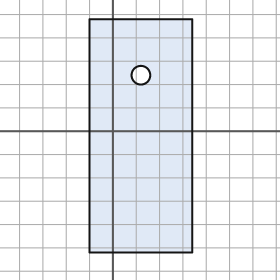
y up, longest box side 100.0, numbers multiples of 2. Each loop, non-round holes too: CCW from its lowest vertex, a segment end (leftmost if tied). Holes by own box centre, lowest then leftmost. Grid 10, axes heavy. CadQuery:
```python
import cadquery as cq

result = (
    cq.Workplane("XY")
    .moveTo(-10.0, -52.0)
    .lineTo(34.0, -52.0)
    .lineTo(34.0, 48.0)
    .lineTo(-10.0, 48.0)
    .close()
    .moveTo(12.0, 24.0)
    .circle(4.0)
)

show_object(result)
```